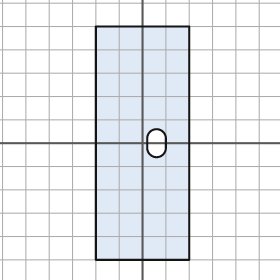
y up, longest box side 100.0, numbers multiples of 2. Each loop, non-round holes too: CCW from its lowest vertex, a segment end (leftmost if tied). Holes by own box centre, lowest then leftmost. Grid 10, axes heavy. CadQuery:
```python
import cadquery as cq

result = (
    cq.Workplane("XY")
    .moveTo(-20.0, -50.0)
    .lineTo(20.0, -50.0)
    .lineTo(20.0, 50.0)
    .lineTo(-20.0, 50.0)
    .close()
    .moveTo(2.0, -2.0)
    .threePointArc((6.0, -6.0), (10.0, -2.0))
    .lineTo(10.0, 2.0)
    .threePointArc((6.0, 6.0), (2.0, 2.0))
    .close()
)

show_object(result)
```